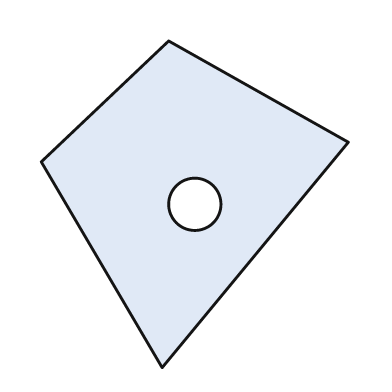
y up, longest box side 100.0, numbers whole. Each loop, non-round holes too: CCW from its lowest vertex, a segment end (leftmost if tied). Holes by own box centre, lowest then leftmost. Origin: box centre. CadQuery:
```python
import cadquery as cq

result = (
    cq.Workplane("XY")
    .moveTo(-10.0, -50.0)
    .lineTo(47.0, 19.0)
    .lineTo(-8.0, 50.0)
    .lineTo(-47.0, 13.0)
    .close()
    .moveTo(0.0, 0.0)
    .circle(8.0)
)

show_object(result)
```